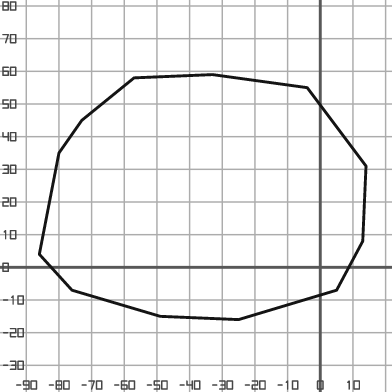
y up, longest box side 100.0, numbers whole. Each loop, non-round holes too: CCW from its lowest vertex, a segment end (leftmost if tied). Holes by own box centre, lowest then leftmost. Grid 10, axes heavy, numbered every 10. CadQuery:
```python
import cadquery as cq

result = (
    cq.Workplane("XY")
    .moveTo(-25.0, -16.0)
    .lineTo(5.0, -7.0)
    .lineTo(13.0, 8.0)
    .lineTo(14.0, 31.0)
    .lineTo(-4.0, 55.0)
    .lineTo(-33.0, 59.0)
    .lineTo(-57.0, 58.0)
    .lineTo(-73.0, 45.0)
    .lineTo(-80.0, 35.0)
    .lineTo(-86.0, 4.0)
    .lineTo(-76.0, -7.0)
    .lineTo(-49.0, -15.0)
    .close()
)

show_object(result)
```